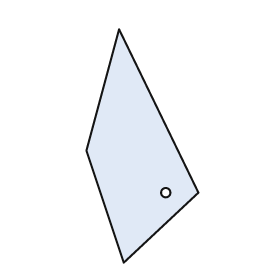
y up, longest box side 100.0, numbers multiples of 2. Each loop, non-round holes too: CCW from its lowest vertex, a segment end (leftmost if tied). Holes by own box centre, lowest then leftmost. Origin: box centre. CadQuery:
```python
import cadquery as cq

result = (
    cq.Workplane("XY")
    .moveTo(-8.0, -50.0)
    .lineTo(24.0, -20.0)
    .lineTo(-10.0, 50.0)
    .lineTo(-24.0, -2.0)
    .close()
    .moveTo(10.0, -20.0)
    .circle(2.0)
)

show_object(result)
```